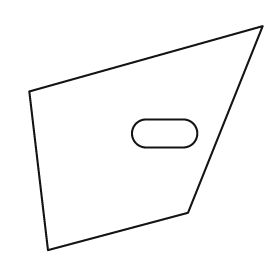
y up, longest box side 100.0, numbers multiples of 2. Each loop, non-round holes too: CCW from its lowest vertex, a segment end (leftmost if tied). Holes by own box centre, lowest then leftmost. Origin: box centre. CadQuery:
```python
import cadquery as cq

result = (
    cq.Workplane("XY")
    .moveTo(-42.0, -48.0)
    .lineTo(18.0, -32.0)
    .lineTo(50.0, 48.0)
    .lineTo(-50.0, 20.0)
    .close()
    .moveTo(0.0, -4.0)
    .lineTo(16.0, -4.0)
    .threePointArc((22.0, 2.0), (16.0, 8.0))
    .lineTo(0.0, 8.0)
    .threePointArc((-6.0, 2.0), (0.0, -4.0))
    .close()
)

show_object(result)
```